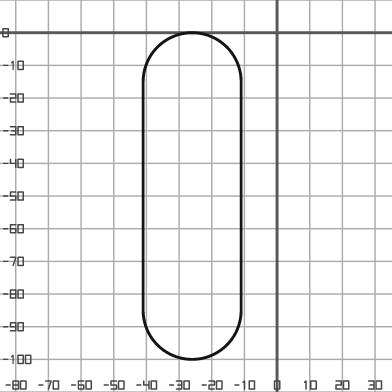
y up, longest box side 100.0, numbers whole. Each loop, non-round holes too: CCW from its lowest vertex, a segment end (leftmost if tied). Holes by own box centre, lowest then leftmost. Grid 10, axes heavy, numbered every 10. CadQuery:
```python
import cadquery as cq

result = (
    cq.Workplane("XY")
    .moveTo(-41.0, -85.0)
    .threePointArc((-26.0, -100.0), (-11.0, -85.0))
    .lineTo(-11.0, -15.0)
    .threePointArc((-26.0, 0.0), (-41.0, -15.0))
    .close()
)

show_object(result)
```